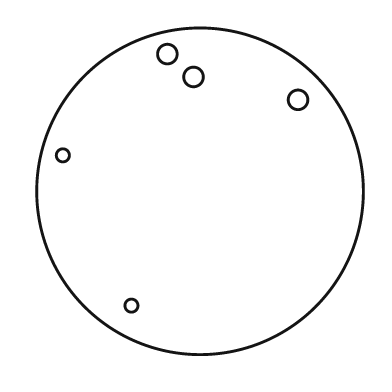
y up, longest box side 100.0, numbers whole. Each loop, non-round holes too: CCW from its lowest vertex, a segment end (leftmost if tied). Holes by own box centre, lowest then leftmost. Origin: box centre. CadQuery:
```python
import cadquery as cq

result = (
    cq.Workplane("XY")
    .moveTo(0.0, 0.0)
    .circle(50.0)
    .moveTo(-21.0, -35.0)
    .circle(2.0)
    .moveTo(-42.0, 11.0)
    .circle(2.0)
    .moveTo(30.0, 28.0)
    .circle(3.0)
    .moveTo(-2.0, 35.0)
    .circle(3.0)
    .moveTo(-10.0, 42.0)
    .circle(3.0)
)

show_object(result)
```